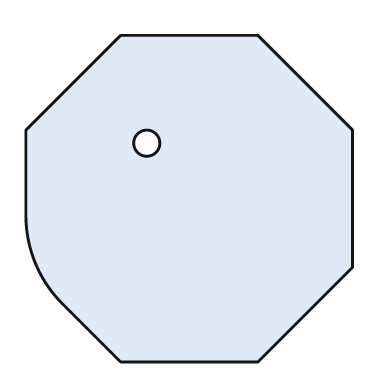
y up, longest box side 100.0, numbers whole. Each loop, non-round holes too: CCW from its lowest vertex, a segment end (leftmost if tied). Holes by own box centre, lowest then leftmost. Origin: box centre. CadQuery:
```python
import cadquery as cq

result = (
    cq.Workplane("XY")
    .moveTo(-21.0, -50.0)
    .lineTo(21.0, -50.0)
    .lineTo(50.0, -21.0)
    .lineTo(50.0, 21.0)
    .lineTo(21.0, 50.0)
    .lineTo(-21.0, 50.0)
    .lineTo(-50.0, 21.0)
    .lineTo(-50.0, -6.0)
    .threePointArc((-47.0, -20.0), (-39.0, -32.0))
    .close()
    .moveTo(-13.0, 17.0)
    .circle(4.0)
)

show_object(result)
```